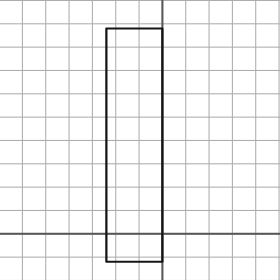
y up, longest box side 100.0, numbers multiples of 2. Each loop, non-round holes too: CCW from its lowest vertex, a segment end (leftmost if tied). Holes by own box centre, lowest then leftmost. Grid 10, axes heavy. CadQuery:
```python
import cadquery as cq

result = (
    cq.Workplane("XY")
    .moveTo(-24.0, -12.0)
    .lineTo(0.0, -12.0)
    .lineTo(0.0, 88.0)
    .lineTo(-24.0, 88.0)
    .close()
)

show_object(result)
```